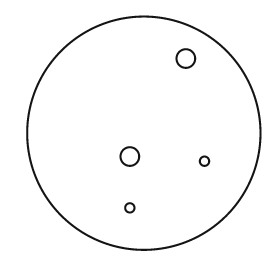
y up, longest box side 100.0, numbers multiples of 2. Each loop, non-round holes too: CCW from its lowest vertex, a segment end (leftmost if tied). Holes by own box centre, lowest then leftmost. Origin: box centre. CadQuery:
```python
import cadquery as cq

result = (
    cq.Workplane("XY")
    .moveTo(0.0, 0.0)
    .circle(50.0)
    .moveTo(-6.0, -32.0)
    .circle(2.0)
    .moveTo(26.0, -12.0)
    .circle(2.0)
    .moveTo(-6.0, -10.0)
    .circle(4.0)
    .moveTo(18.0, 32.0)
    .circle(4.0)
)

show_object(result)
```